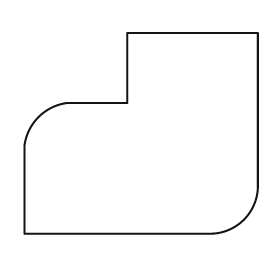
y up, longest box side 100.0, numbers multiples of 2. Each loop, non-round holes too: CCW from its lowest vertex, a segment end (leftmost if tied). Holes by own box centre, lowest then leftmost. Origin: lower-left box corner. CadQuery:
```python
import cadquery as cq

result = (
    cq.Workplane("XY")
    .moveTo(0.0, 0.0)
    .lineTo(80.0, 0.0)
    .threePointArc((94.0, 6.0), (100.0, 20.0))
    .lineTo(100.0, 86.0)
    .lineTo(44.0, 86.0)
    .lineTo(44.0, 56.0)
    .lineTo(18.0, 56.0)
    .threePointArc((6.0, 50.0), (0.0, 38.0))
    .close()
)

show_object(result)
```